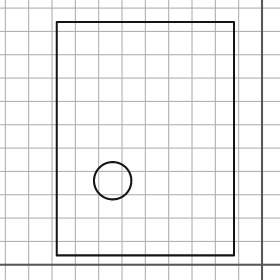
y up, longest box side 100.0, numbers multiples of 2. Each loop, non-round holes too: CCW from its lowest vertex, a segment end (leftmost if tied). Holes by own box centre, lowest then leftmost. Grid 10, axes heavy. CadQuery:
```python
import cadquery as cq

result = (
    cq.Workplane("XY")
    .moveTo(-88.0, 4.0)
    .lineTo(-12.0, 4.0)
    .lineTo(-12.0, 104.0)
    .lineTo(-88.0, 104.0)
    .close()
    .moveTo(-64.0, 36.0)
    .circle(8.0)
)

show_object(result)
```